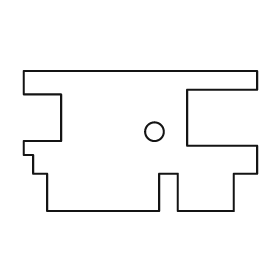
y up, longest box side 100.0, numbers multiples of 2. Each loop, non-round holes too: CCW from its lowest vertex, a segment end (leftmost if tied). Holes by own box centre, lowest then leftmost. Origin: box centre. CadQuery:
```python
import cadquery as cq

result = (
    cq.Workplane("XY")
    .moveTo(-40.0, -30.0)
    .lineTo(8.0, -30.0)
    .lineTo(8.0, -14.0)
    .lineTo(16.0, -14.0)
    .lineTo(16.0, -30.0)
    .lineTo(40.0, -30.0)
    .lineTo(40.0, -14.0)
    .lineTo(50.0, -14.0)
    .lineTo(50.0, -2.0)
    .lineTo(20.0, -2.0)
    .lineTo(20.0, 22.0)
    .lineTo(50.0, 22.0)
    .lineTo(50.0, 30.0)
    .lineTo(-50.0, 30.0)
    .lineTo(-50.0, 20.0)
    .lineTo(-34.0, 20.0)
    .lineTo(-34.0, 0.0)
    .lineTo(-50.0, 0.0)
    .lineTo(-50.0, -6.0)
    .lineTo(-46.0, -6.0)
    .lineTo(-46.0, -14.0)
    .lineTo(-40.0, -14.0)
    .close()
    .moveTo(6.0, 4.0)
    .circle(4.0)
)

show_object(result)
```